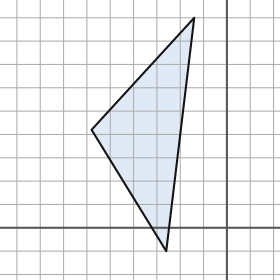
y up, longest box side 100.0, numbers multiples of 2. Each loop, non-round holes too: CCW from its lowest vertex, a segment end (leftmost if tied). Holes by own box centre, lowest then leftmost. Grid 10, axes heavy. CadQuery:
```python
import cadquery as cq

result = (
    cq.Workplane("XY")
    .moveTo(-26.0, -10.0)
    .lineTo(-14.0, 90.0)
    .lineTo(-58.0, 42.0)
    .close()
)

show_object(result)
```